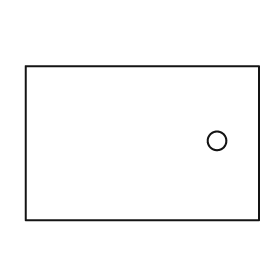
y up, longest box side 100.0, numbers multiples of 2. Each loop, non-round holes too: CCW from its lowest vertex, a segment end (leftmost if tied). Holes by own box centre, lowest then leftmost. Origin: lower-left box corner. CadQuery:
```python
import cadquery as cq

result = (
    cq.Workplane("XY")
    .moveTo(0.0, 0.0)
    .lineTo(100.0, 0.0)
    .lineTo(100.0, 66.0)
    .lineTo(0.0, 66.0)
    .close()
    .moveTo(82.0, 34.0)
    .circle(4.0)
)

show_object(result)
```